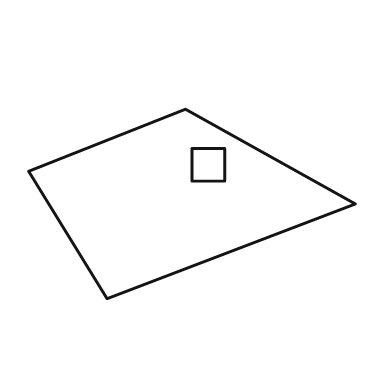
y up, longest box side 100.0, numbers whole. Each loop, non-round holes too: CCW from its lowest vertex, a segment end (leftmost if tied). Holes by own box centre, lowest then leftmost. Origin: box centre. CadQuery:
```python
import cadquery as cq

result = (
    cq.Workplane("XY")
    .moveTo(-26.0, -29.0)
    .lineTo(50.0, 0.0)
    .lineTo(-2.0, 29.0)
    .lineTo(-50.0, 10.0)
    .close()
    .moveTo(0.0, 7.0)
    .lineTo(10.0, 7.0)
    .lineTo(10.0, 17.0)
    .lineTo(0.0, 17.0)
    .close()
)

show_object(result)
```